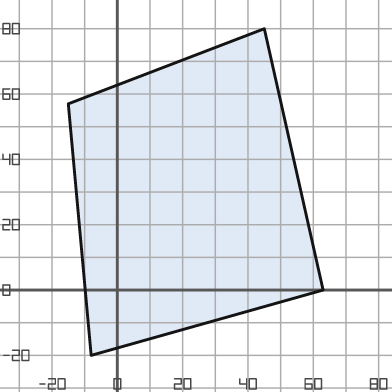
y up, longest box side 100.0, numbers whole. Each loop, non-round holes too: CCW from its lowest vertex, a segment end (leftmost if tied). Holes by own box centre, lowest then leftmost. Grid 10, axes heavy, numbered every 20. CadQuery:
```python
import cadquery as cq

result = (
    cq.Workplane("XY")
    .moveTo(-8.0, -20.0)
    .lineTo(63.0, 0.0)
    .lineTo(45.0, 80.0)
    .lineTo(-15.0, 57.0)
    .close()
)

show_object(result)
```